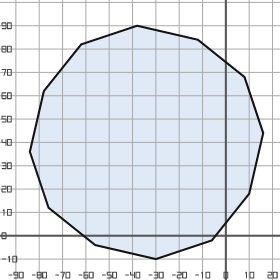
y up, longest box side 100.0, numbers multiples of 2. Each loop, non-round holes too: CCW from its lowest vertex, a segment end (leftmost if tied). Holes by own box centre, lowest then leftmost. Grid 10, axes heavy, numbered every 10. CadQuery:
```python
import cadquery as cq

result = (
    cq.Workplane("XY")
    .moveTo(-30.0, -10.0)
    .lineTo(-6.0, -2.0)
    .lineTo(10.0, 18.0)
    .lineTo(16.0, 44.0)
    .lineTo(8.0, 68.0)
    .lineTo(-12.0, 84.0)
    .lineTo(-38.0, 90.0)
    .lineTo(-62.0, 82.0)
    .lineTo(-78.0, 62.0)
    .lineTo(-84.0, 36.0)
    .lineTo(-76.0, 12.0)
    .lineTo(-56.0, -4.0)
    .close()
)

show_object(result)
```